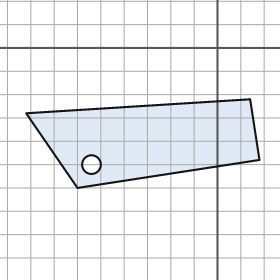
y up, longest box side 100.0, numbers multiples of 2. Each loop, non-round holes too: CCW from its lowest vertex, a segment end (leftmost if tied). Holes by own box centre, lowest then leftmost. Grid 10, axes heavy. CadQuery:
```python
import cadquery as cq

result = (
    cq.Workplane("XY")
    .moveTo(-60.0, -60.0)
    .lineTo(18.0, -48.0)
    .lineTo(14.0, -22.0)
    .lineTo(-82.0, -28.0)
    .close()
    .moveTo(-54.0, -50.0)
    .circle(4.0)
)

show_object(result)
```